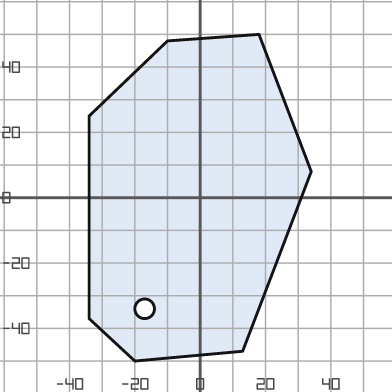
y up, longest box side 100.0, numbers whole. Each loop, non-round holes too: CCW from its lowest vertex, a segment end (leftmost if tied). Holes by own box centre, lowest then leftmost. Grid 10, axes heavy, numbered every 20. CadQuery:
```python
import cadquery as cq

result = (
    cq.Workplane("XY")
    .moveTo(-20.0, -50.0)
    .lineTo(13.0, -47.0)
    .lineTo(34.0, 8.0)
    .lineTo(18.0, 50.0)
    .lineTo(-10.0, 48.0)
    .lineTo(-34.0, 25.0)
    .lineTo(-34.0, -37.0)
    .close()
    .moveTo(-17.0, -34.0)
    .circle(3.0)
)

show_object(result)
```